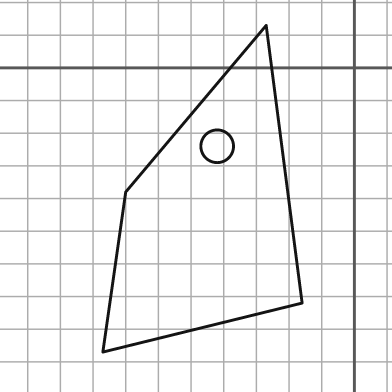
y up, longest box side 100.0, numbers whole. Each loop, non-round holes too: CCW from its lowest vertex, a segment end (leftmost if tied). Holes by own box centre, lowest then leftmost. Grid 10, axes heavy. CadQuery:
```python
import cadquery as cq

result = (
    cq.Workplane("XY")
    .moveTo(-77.0, -87.0)
    .lineTo(-16.0, -72.0)
    .lineTo(-27.0, 13.0)
    .lineTo(-70.0, -38.0)
    .close()
    .moveTo(-42.0, -24.0)
    .circle(5.0)
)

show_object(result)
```